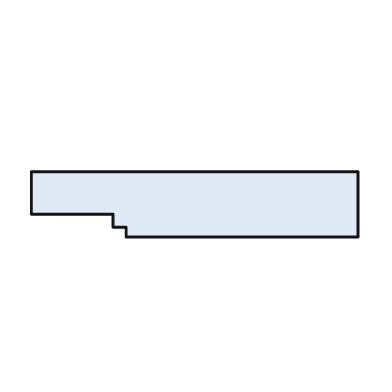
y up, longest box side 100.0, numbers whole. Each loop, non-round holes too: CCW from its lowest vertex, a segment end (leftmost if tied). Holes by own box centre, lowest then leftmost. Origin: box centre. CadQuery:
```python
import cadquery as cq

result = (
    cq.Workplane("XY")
    .moveTo(-21.0, -10.0)
    .lineTo(50.0, -10.0)
    .lineTo(50.0, 10.0)
    .lineTo(-50.0, 10.0)
    .lineTo(-50.0, -3.0)
    .lineTo(-25.0, -3.0)
    .lineTo(-25.0, -7.0)
    .lineTo(-21.0, -7.0)
    .close()
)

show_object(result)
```